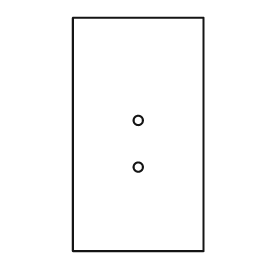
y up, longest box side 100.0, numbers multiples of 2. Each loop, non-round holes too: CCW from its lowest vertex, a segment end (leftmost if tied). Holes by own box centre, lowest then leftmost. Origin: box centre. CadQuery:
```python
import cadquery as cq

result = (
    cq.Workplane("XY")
    .moveTo(-28.0, -50.0)
    .lineTo(28.0, -50.0)
    .lineTo(28.0, 50.0)
    .lineTo(-28.0, 50.0)
    .close()
    .moveTo(0.0, -14.0)
    .circle(2.0)
    .moveTo(0.0, 6.0)
    .circle(2.0)
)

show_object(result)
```